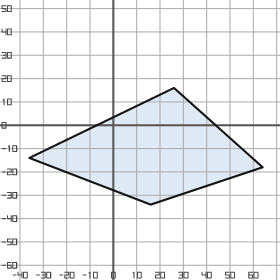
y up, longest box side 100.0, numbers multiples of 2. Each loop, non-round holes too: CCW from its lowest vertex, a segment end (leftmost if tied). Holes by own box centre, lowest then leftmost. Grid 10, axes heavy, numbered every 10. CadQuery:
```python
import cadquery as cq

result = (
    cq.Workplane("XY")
    .moveTo(16.0, -34.0)
    .lineTo(64.0, -18.0)
    .lineTo(26.0, 16.0)
    .lineTo(-36.0, -14.0)
    .close()
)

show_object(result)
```